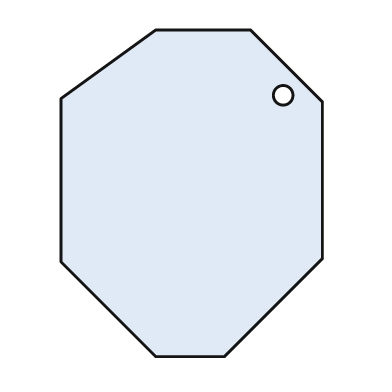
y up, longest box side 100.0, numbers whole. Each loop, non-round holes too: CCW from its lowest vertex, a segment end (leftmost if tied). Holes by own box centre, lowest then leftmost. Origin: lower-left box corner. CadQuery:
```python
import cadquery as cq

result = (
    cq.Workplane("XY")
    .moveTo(29.0, 0.0)
    .lineTo(50.0, 0.0)
    .lineTo(80.0, 30.0)
    .lineTo(80.0, 78.0)
    .lineTo(58.0, 100.0)
    .lineTo(29.0, 100.0)
    .lineTo(0.0, 79.0)
    .lineTo(0.0, 29.0)
    .close()
    .moveTo(68.0, 80.0)
    .circle(3.0)
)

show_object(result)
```